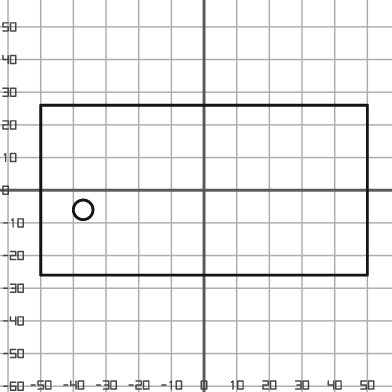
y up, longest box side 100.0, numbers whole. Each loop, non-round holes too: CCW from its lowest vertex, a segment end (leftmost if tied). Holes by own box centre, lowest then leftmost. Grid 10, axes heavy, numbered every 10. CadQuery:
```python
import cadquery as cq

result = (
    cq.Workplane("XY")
    .moveTo(-50.0, -26.0)
    .lineTo(50.0, -26.0)
    .lineTo(50.0, 26.0)
    .lineTo(-50.0, 26.0)
    .close()
    .moveTo(-37.0, -6.0)
    .circle(3.0)
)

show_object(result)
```